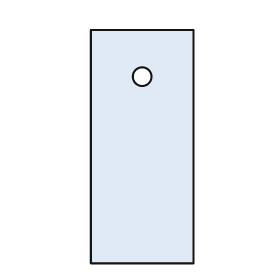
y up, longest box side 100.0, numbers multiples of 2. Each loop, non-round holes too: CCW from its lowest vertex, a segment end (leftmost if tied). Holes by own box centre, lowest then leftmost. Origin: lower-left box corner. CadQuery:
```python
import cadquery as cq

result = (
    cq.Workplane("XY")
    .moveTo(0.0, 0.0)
    .lineTo(44.0, 0.0)
    .lineTo(44.0, 100.0)
    .lineTo(0.0, 100.0)
    .close()
    .moveTo(22.0, 80.0)
    .circle(4.0)
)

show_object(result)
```